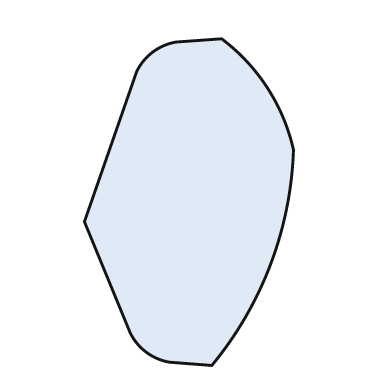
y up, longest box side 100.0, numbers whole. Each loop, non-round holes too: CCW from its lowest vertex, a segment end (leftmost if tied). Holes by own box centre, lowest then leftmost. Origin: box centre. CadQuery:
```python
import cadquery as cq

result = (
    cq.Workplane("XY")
    .moveTo(7.0, -50.0)
    .threePointArc((25.0, -19.0), (32.0, 16.0))
    .threePointArc((24.0, 35.0), (10.0, 50.0))
    .lineTo(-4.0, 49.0)
    .threePointArc((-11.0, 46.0), (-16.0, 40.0))
    .lineTo(-32.0, -6.0)
    .lineTo(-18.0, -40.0)
    .threePointArc((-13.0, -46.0), (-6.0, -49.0))
    .close()
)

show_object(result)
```